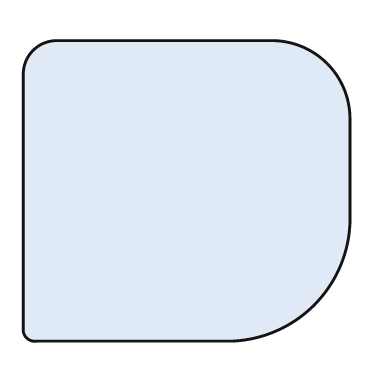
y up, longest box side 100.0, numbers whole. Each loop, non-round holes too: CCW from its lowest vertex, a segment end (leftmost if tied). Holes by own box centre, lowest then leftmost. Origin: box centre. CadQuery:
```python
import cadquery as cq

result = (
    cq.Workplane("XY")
    .moveTo(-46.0, -46.0)
    .lineTo(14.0, -46.0)
    .threePointArc((39.0, -35.0), (50.0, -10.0))
    .lineTo(50.0, 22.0)
    .threePointArc((43.0, 39.0), (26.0, 46.0))
    .lineTo(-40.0, 46.0)
    .threePointArc((-47.0, 43.0), (-50.0, 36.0))
    .lineTo(-50.0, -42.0)
    .threePointArc((-49.0, -45.0), (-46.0, -46.0))
    .close()
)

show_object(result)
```